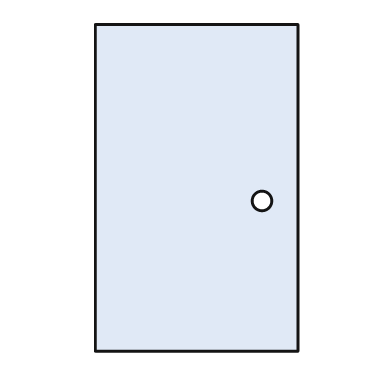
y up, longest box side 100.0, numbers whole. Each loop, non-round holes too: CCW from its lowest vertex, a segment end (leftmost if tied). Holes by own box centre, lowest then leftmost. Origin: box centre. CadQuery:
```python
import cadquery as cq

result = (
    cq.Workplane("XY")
    .moveTo(-31.0, -50.0)
    .lineTo(31.0, -50.0)
    .lineTo(31.0, 50.0)
    .lineTo(-31.0, 50.0)
    .close()
    .moveTo(20.0, -4.0)
    .circle(3.0)
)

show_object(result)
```